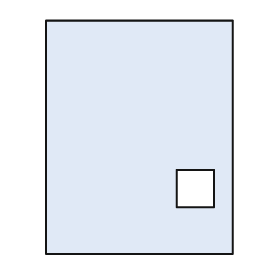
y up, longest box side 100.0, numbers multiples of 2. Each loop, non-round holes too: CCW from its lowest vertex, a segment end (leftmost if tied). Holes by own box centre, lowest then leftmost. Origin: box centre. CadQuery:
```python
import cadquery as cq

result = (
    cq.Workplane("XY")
    .moveTo(-40.0, -50.0)
    .lineTo(40.0, -50.0)
    .lineTo(40.0, 50.0)
    .lineTo(-40.0, 50.0)
    .close()
    .moveTo(16.0, -30.0)
    .lineTo(32.0, -30.0)
    .lineTo(32.0, -14.0)
    .lineTo(16.0, -14.0)
    .close()
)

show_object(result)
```